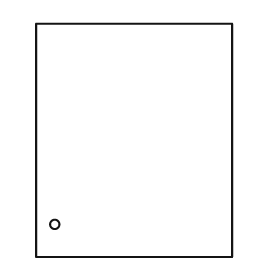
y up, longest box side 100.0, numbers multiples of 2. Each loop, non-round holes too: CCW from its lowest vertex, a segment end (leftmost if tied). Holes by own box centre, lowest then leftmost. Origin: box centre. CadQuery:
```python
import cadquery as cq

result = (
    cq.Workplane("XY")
    .moveTo(-42.0, -50.0)
    .lineTo(42.0, -50.0)
    .lineTo(42.0, 50.0)
    .lineTo(-42.0, 50.0)
    .close()
    .moveTo(-34.0, -36.0)
    .circle(2.0)
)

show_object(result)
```